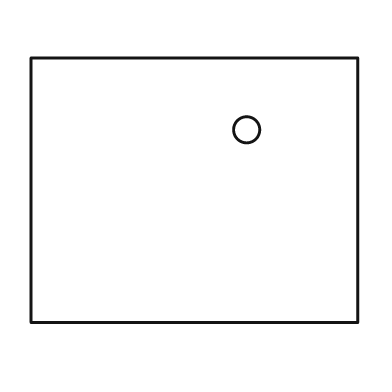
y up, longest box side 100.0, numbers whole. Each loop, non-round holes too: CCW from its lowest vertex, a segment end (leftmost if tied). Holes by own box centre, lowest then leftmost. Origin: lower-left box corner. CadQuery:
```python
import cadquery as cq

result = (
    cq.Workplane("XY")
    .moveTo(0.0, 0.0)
    .lineTo(100.0, 0.0)
    .lineTo(100.0, 81.0)
    .lineTo(0.0, 81.0)
    .close()
    .moveTo(66.0, 59.0)
    .circle(4.0)
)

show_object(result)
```